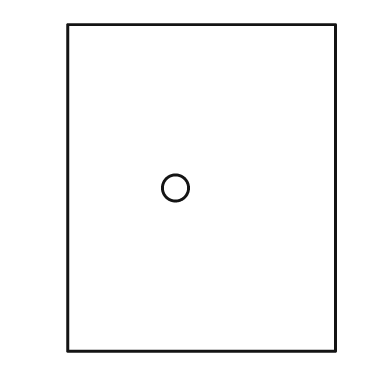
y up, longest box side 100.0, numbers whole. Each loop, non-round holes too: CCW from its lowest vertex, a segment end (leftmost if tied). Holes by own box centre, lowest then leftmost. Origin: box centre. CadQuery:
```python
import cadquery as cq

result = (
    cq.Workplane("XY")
    .moveTo(-41.0, -50.0)
    .lineTo(41.0, -50.0)
    .lineTo(41.0, 50.0)
    .lineTo(-41.0, 50.0)
    .close()
    .moveTo(-8.0, 0.0)
    .circle(4.0)
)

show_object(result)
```